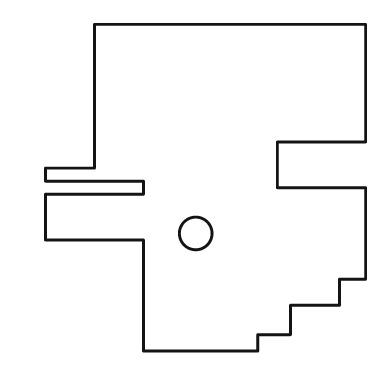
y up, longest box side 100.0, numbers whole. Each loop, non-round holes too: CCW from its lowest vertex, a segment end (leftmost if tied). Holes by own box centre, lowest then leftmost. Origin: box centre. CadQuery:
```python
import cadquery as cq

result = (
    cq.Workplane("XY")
    .moveTo(-19.0, -50.0)
    .lineTo(16.0, -50.0)
    .lineTo(16.0, -45.0)
    .lineTo(26.0, -45.0)
    .lineTo(26.0, -36.0)
    .lineTo(41.0, -36.0)
    .lineTo(41.0, -28.0)
    .lineTo(49.0, -28.0)
    .lineTo(49.0, 0.0)
    .lineTo(22.0, 0.0)
    .lineTo(22.0, 14.0)
    .lineTo(49.0, 14.0)
    .lineTo(49.0, 50.0)
    .lineTo(-34.0, 50.0)
    .lineTo(-34.0, 6.0)
    .lineTo(-49.0, 6.0)
    .lineTo(-49.0, 2.0)
    .lineTo(-19.0, 2.0)
    .lineTo(-19.0, -2.0)
    .lineTo(-49.0, -2.0)
    .lineTo(-49.0, -16.0)
    .lineTo(-19.0, -16.0)
    .close()
    .moveTo(-3.0, -14.0)
    .circle(5.0)
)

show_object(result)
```